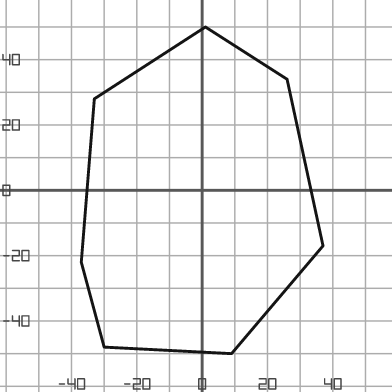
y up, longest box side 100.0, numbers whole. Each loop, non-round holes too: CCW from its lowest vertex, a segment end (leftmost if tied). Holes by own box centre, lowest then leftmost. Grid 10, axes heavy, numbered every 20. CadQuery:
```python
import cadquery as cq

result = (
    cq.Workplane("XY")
    .moveTo(9.0, -50.0)
    .lineTo(37.0, -17.0)
    .lineTo(26.0, 34.0)
    .lineTo(1.0, 50.0)
    .lineTo(-33.0, 28.0)
    .lineTo(-37.0, -22.0)
    .lineTo(-30.0, -48.0)
    .close()
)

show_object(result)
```